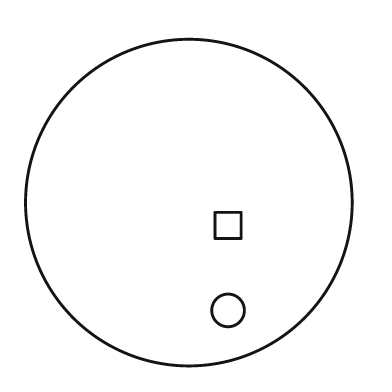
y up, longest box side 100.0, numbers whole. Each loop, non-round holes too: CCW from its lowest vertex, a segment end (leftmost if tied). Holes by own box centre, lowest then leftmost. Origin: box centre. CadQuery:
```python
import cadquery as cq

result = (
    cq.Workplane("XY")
    .moveTo(0.0, 0.0)
    .circle(50.0)
    .moveTo(12.0, -33.0)
    .circle(5.0)
    .moveTo(8.0, -11.0)
    .lineTo(16.0, -11.0)
    .lineTo(16.0, -3.0)
    .lineTo(8.0, -3.0)
    .close()
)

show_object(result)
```